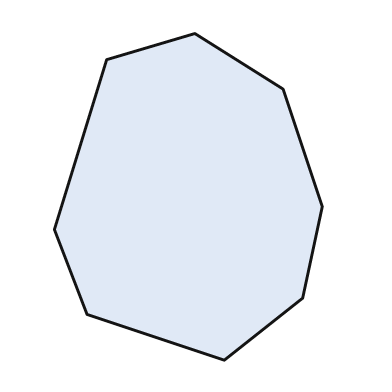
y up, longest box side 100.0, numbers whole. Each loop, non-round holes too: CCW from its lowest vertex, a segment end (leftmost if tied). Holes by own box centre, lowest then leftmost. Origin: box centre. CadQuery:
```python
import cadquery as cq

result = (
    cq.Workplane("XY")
    .moveTo(11.0, -50.0)
    .lineTo(35.0, -31.0)
    .lineTo(41.0, -3.0)
    .lineTo(29.0, 33.0)
    .lineTo(2.0, 50.0)
    .lineTo(-25.0, 42.0)
    .lineTo(-41.0, -10.0)
    .lineTo(-31.0, -36.0)
    .close()
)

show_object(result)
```